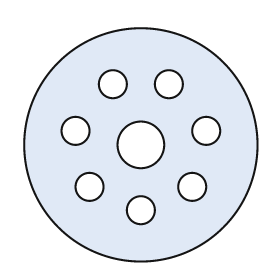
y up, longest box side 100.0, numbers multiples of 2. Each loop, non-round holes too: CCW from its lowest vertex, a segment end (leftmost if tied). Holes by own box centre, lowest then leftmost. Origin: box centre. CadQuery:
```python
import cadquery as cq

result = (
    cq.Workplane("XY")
    .moveTo(0.0, 0.0)
    .circle(50.0)
    .moveTo(0.0, -28.0)
    .circle(6.0)
    .moveTo(-22.0, -18.0)
    .circle(6.0)
    .moveTo(22.0, -18.0)
    .circle(6.0)
    .moveTo(0.0, 0.0)
    .circle(10.0)
    .moveTo(-28.0, 6.0)
    .circle(6.0)
    .moveTo(28.0, 6.0)
    .circle(6.0)
    .moveTo(-12.0, 26.0)
    .circle(6.0)
    .moveTo(12.0, 26.0)
    .circle(6.0)
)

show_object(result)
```